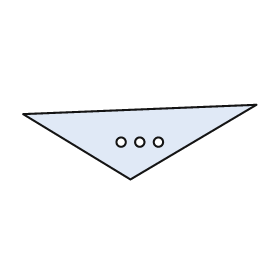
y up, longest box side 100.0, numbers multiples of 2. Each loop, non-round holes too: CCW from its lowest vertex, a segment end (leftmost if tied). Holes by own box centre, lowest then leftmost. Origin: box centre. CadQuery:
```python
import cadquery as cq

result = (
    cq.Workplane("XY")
    .moveTo(-4.0, -16.0)
    .lineTo(50.0, 16.0)
    .lineTo(-50.0, 12.0)
    .close()
    .moveTo(-8.0, 0.0)
    .circle(2.0)
    .moveTo(0.0, 0.0)
    .circle(2.0)
    .moveTo(8.0, 0.0)
    .circle(2.0)
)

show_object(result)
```